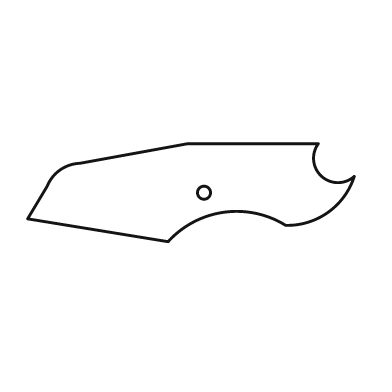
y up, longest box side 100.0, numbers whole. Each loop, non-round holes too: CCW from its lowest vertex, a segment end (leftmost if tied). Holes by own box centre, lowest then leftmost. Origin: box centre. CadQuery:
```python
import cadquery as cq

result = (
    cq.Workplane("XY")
    .moveTo(-7.0, -15.0)
    .threePointArc((10.0, -6.0), (29.0, -10.0))
    .threePointArc((42.0, -6.0), (50.0, 5.0))
    .threePointArc((40.0, 5.0), (39.0, 15.0))
    .lineTo(-1.0, 15.0)
    .lineTo(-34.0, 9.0)
    .threePointArc((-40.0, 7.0), (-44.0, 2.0))
    .lineTo(-50.0, -8.0)
    .close()
    .moveTo(4.0, 0.0)
    .circle(2.0)
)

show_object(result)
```